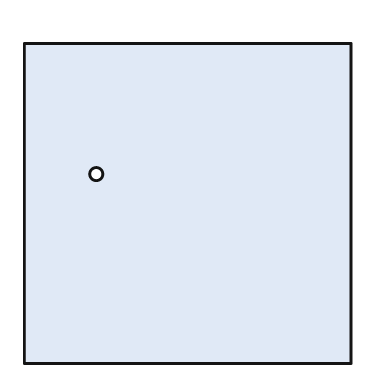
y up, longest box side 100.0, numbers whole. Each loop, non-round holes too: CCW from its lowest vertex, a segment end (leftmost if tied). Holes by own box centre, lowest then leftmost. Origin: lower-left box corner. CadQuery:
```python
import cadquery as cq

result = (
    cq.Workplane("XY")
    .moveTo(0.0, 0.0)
    .lineTo(100.0, 0.0)
    .lineTo(100.0, 98.0)
    .lineTo(0.0, 98.0)
    .close()
    .moveTo(22.0, 58.0)
    .circle(2.0)
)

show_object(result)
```